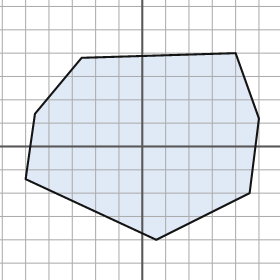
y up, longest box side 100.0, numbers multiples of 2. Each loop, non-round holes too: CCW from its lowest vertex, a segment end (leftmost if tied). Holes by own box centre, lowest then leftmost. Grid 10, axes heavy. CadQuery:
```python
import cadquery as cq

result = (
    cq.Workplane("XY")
    .moveTo(6.0, -40.0)
    .lineTo(46.0, -20.0)
    .lineTo(50.0, 12.0)
    .lineTo(40.0, 40.0)
    .lineTo(-26.0, 38.0)
    .lineTo(-46.0, 14.0)
    .lineTo(-50.0, -14.0)
    .close()
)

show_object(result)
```